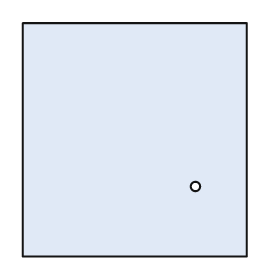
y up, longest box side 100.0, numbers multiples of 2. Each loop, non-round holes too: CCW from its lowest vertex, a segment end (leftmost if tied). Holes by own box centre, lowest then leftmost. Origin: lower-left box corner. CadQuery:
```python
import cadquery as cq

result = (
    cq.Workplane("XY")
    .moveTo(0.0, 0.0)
    .lineTo(96.0, 0.0)
    .lineTo(96.0, 100.0)
    .lineTo(0.0, 100.0)
    .close()
    .moveTo(74.0, 30.0)
    .circle(2.0)
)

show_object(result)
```